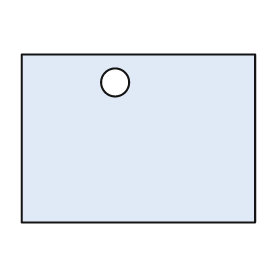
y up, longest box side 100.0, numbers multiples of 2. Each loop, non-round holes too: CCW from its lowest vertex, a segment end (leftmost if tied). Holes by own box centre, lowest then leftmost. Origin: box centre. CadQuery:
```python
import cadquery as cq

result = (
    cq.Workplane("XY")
    .moveTo(-50.0, -36.0)
    .lineTo(50.0, -36.0)
    .lineTo(50.0, 36.0)
    .lineTo(-50.0, 36.0)
    .close()
    .moveTo(-10.0, 24.0)
    .circle(6.0)
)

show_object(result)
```